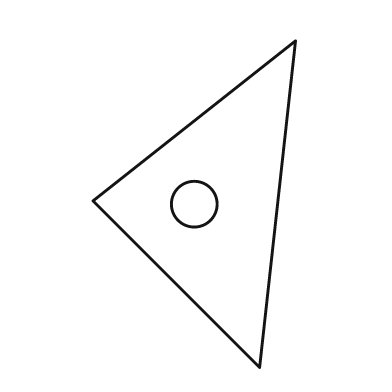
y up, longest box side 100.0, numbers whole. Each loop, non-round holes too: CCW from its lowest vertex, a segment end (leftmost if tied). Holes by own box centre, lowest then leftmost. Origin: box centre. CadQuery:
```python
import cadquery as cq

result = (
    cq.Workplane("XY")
    .moveTo(20.0, -50.0)
    .lineTo(31.0, 50.0)
    .lineTo(-31.0, 1.0)
    .close()
    .moveTo(0.0, 0.0)
    .circle(7.0)
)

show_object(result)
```